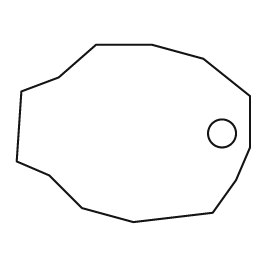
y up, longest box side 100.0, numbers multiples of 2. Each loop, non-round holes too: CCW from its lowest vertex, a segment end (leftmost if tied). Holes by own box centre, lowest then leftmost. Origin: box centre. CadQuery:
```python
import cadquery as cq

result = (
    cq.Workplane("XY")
    .moveTo(0.0, -38.0)
    .lineTo(34.0, -34.0)
    .lineTo(44.0, -20.0)
    .lineTo(50.0, -6.0)
    .lineTo(50.0, 16.0)
    .lineTo(30.0, 32.0)
    .lineTo(8.0, 38.0)
    .lineTo(-16.0, 38.0)
    .lineTo(-32.0, 24.0)
    .lineTo(-48.0, 18.0)
    .lineTo(-50.0, -12.0)
    .lineTo(-36.0, -18.0)
    .lineTo(-22.0, -32.0)
    .close()
    .moveTo(38.0, 0.0)
    .circle(6.0)
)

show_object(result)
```